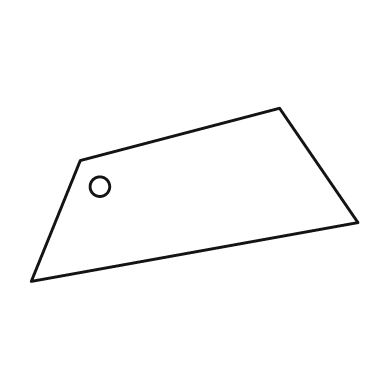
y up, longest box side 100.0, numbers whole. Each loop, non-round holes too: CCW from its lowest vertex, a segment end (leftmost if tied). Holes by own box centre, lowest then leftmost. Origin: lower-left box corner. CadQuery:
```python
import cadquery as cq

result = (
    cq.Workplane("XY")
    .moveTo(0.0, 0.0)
    .lineTo(100.0, 18.0)
    .lineTo(76.0, 53.0)
    .lineTo(15.0, 37.0)
    .close()
    .moveTo(21.0, 29.0)
    .circle(3.0)
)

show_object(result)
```